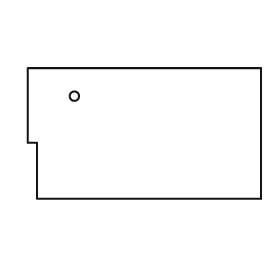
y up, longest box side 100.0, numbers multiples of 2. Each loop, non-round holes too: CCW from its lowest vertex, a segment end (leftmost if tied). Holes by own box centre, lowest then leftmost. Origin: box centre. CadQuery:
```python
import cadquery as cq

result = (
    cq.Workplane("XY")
    .moveTo(-46.0, -28.0)
    .lineTo(50.0, -28.0)
    .lineTo(50.0, 28.0)
    .lineTo(-50.0, 28.0)
    .lineTo(-50.0, -4.0)
    .lineTo(-46.0, -4.0)
    .close()
    .moveTo(-30.0, 16.0)
    .circle(2.0)
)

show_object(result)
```